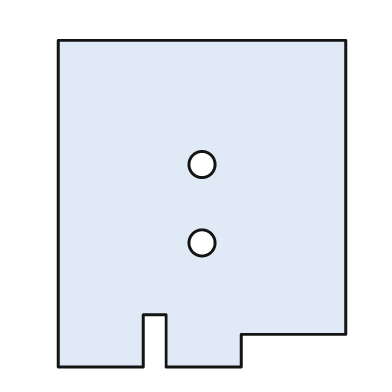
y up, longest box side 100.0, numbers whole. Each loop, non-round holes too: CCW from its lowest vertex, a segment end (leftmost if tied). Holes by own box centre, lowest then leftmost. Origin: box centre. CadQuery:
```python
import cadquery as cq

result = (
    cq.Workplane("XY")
    .moveTo(-44.0, -50.0)
    .lineTo(-18.0, -50.0)
    .lineTo(-18.0, -34.0)
    .lineTo(-11.0, -34.0)
    .lineTo(-11.0, -50.0)
    .lineTo(12.0, -50.0)
    .lineTo(12.0, -40.0)
    .lineTo(44.0, -40.0)
    .lineTo(44.0, 50.0)
    .lineTo(-44.0, 50.0)
    .close()
    .moveTo(0.0, -12.0)
    .circle(4.0)
    .moveTo(0.0, 12.0)
    .circle(4.0)
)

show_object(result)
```